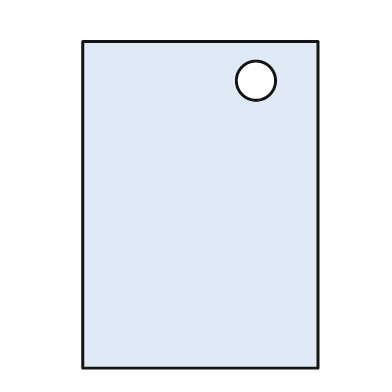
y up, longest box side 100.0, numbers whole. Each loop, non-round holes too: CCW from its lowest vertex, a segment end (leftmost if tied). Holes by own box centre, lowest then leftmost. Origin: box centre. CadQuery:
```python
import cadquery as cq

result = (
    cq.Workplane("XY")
    .moveTo(-36.0, -50.0)
    .lineTo(36.0, -50.0)
    .lineTo(36.0, 50.0)
    .lineTo(-36.0, 50.0)
    .close()
    .moveTo(17.0, 38.0)
    .circle(6.0)
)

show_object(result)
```